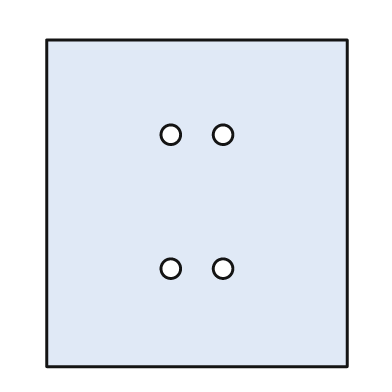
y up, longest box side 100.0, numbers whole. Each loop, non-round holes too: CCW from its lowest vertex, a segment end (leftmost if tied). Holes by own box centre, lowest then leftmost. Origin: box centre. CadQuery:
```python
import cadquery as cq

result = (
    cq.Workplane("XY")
    .moveTo(-46.0, -50.0)
    .lineTo(46.0, -50.0)
    .lineTo(46.0, 50.0)
    .lineTo(-46.0, 50.0)
    .close()
    .moveTo(-8.0, -20.0)
    .circle(3.0)
    .moveTo(8.0, -20.0)
    .circle(3.0)
    .moveTo(-8.0, 21.0)
    .circle(3.0)
    .moveTo(8.0, 21.0)
    .circle(3.0)
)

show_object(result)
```